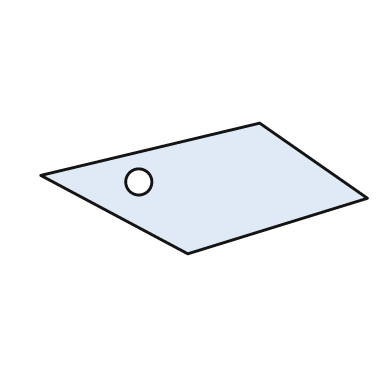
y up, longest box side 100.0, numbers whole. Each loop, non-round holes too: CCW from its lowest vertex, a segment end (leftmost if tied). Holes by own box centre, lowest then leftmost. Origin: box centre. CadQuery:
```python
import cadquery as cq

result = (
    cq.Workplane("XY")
    .moveTo(-5.0, -20.0)
    .lineTo(50.0, -3.0)
    .lineTo(17.0, 20.0)
    .lineTo(-50.0, 4.0)
    .close()
    .moveTo(-20.0, 2.0)
    .circle(4.0)
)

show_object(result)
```